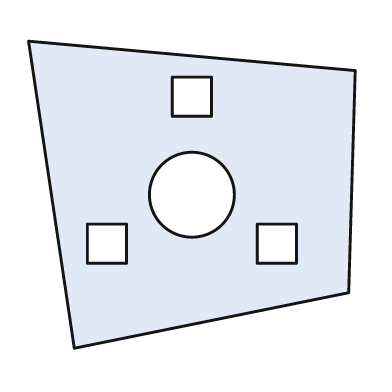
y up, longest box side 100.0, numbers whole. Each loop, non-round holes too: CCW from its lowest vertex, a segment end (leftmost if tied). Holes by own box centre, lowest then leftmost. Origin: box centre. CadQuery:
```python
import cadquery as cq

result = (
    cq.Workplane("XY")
    .moveTo(-36.0, -47.0)
    .lineTo(48.0, -30.0)
    .lineTo(50.0, 38.0)
    .lineTo(-50.0, 47.0)
    .close()
    .moveTo(-32.0, -21.0)
    .lineTo(-20.0, -21.0)
    .lineTo(-20.0, -9.0)
    .lineTo(-32.0, -9.0)
    .close()
    .moveTo(20.0, -21.0)
    .lineTo(32.0, -21.0)
    .lineTo(32.0, -9.0)
    .lineTo(20.0, -9.0)
    .close()
    .moveTo(0.0, 0.0)
    .circle(13.0)
    .moveTo(-6.0, 24.0)
    .lineTo(6.0, 24.0)
    .lineTo(6.0, 36.0)
    .lineTo(-6.0, 36.0)
    .close()
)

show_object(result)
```